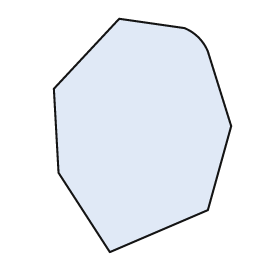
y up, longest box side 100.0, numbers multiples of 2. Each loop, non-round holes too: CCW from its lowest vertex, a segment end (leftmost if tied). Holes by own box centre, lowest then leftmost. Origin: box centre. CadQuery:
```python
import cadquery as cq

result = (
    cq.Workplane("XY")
    .moveTo(-14.0, -50.0)
    .lineTo(28.0, -32.0)
    .lineTo(38.0, 4.0)
    .lineTo(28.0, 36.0)
    .threePointArc((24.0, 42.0), (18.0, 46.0))
    .lineTo(-10.0, 50.0)
    .lineTo(-38.0, 20.0)
    .lineTo(-36.0, -16.0)
    .close()
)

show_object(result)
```